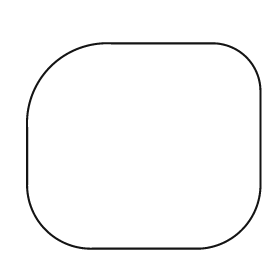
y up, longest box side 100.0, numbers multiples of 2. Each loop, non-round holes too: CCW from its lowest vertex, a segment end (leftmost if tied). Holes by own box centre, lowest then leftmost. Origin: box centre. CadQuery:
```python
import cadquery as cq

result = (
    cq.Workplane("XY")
    .moveTo(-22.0, -44.0)
    .lineTo(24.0, -44.0)
    .threePointArc((42.0, -36.0), (50.0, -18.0))
    .lineTo(50.0, 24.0)
    .threePointArc((44.0, 38.0), (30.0, 44.0))
    .lineTo(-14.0, 44.0)
    .threePointArc((-40.0, 34.0), (-50.0, 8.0))
    .lineTo(-50.0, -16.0)
    .threePointArc((-42.0, -36.0), (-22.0, -44.0))
    .close()
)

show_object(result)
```